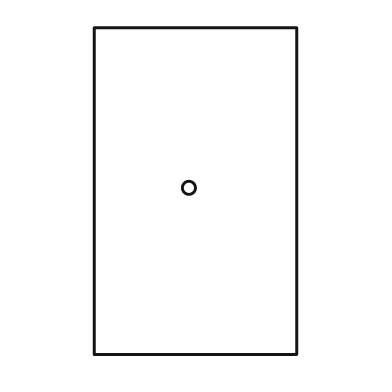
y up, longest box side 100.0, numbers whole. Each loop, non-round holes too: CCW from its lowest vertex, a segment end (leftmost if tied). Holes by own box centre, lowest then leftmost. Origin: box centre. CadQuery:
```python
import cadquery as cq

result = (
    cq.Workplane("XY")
    .moveTo(-31.0, -50.0)
    .lineTo(31.0, -50.0)
    .lineTo(31.0, 50.0)
    .lineTo(-31.0, 50.0)
    .close()
    .moveTo(-2.0, 1.0)
    .circle(2.0)
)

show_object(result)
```